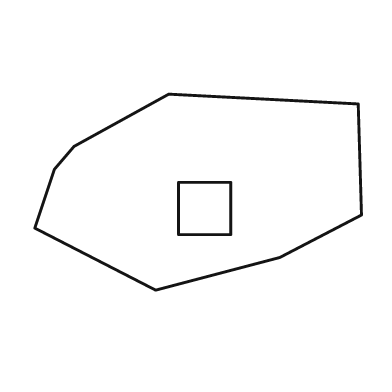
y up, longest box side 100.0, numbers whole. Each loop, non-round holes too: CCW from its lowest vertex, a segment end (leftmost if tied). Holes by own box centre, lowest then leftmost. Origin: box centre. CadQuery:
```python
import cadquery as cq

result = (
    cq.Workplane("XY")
    .moveTo(-13.0, -30.0)
    .lineTo(25.0, -20.0)
    .lineTo(50.0, -7.0)
    .lineTo(49.0, 27.0)
    .lineTo(-9.0, 30.0)
    .lineTo(-38.0, 14.0)
    .lineTo(-44.0, 7.0)
    .lineTo(-50.0, -11.0)
    .close()
    .moveTo(-6.0, -13.0)
    .lineTo(10.0, -13.0)
    .lineTo(10.0, 3.0)
    .lineTo(-6.0, 3.0)
    .close()
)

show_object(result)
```